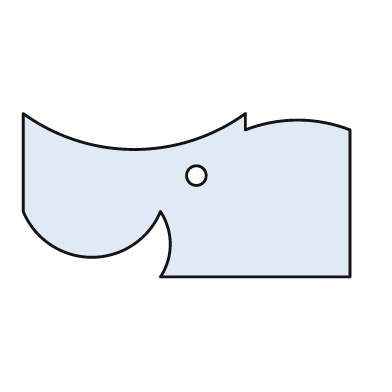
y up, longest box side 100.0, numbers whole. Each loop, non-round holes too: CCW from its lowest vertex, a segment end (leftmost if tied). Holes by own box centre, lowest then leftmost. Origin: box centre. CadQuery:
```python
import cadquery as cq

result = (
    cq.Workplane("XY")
    .moveTo(-8.0, -25.0)
    .lineTo(50.0, -25.0)
    .lineTo(50.0, 20.0)
    .threePointArc((34.0, 23.0), (18.0, 20.0))
    .lineTo(18.0, 25.0)
    .threePointArc((-16.0, 14.0), (-50.0, 25.0))
    .lineTo(-50.0, -5.0)
    .threePointArc((-29.0, -19.0), (-8.0, -5.0))
    .threePointArc((-5.0, -15.0), (-8.0, -25.0))
    .close()
    .moveTo(3.0, 6.0)
    .circle(3.0)
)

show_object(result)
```